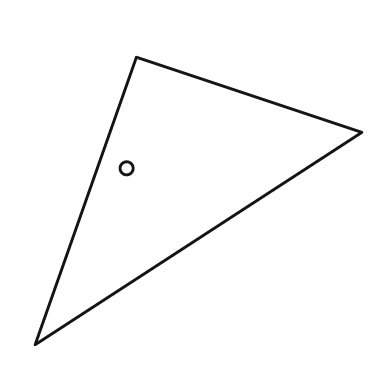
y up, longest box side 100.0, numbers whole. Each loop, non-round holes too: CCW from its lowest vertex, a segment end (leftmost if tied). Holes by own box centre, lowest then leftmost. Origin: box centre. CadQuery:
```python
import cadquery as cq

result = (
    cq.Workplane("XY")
    .moveTo(-50.0, -44.0)
    .lineTo(50.0, 21.0)
    .lineTo(-19.0, 44.0)
    .close()
    .moveTo(-22.0, 10.0)
    .circle(2.0)
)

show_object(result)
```